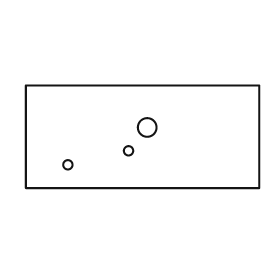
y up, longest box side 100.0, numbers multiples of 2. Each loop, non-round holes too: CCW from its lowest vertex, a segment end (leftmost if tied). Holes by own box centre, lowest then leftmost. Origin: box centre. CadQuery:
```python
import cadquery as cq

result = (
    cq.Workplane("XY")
    .moveTo(-50.0, -22.0)
    .lineTo(50.0, -22.0)
    .lineTo(50.0, 22.0)
    .lineTo(-50.0, 22.0)
    .close()
    .moveTo(-32.0, -12.0)
    .circle(2.0)
    .moveTo(-6.0, -6.0)
    .circle(2.0)
    .moveTo(2.0, 4.0)
    .circle(4.0)
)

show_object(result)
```